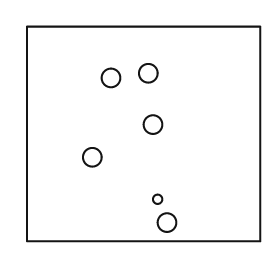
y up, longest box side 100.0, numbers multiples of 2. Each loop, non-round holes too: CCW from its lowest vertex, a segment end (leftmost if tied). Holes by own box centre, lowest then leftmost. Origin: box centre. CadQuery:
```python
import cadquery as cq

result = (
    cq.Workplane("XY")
    .moveTo(-50.0, -46.0)
    .lineTo(50.0, -46.0)
    .lineTo(50.0, 46.0)
    .lineTo(-50.0, 46.0)
    .close()
    .moveTo(10.0, -38.0)
    .circle(4.0)
    .moveTo(6.0, -28.0)
    .circle(2.0)
    .moveTo(-22.0, -10.0)
    .circle(4.0)
    .moveTo(4.0, 4.0)
    .circle(4.0)
    .moveTo(-14.0, 24.0)
    .circle(4.0)
    .moveTo(2.0, 26.0)
    .circle(4.0)
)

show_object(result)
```